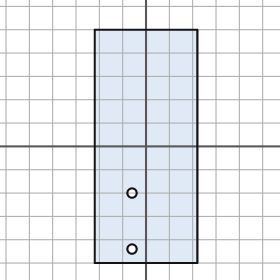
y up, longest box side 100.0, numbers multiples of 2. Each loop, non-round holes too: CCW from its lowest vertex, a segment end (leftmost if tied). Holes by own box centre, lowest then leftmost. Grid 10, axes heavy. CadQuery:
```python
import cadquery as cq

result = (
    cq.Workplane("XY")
    .moveTo(-22.0, -50.0)
    .lineTo(22.0, -50.0)
    .lineTo(22.0, 50.0)
    .lineTo(-22.0, 50.0)
    .close()
    .moveTo(-6.0, -44.0)
    .circle(2.0)
    .moveTo(-6.0, -20.0)
    .circle(2.0)
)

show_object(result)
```